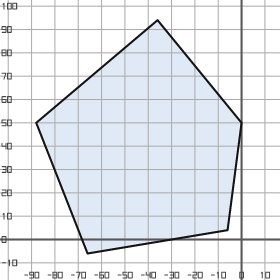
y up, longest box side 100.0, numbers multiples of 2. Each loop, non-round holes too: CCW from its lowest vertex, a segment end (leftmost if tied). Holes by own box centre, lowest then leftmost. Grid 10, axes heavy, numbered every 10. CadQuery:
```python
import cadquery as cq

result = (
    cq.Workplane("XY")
    .moveTo(-66.0, -6.0)
    .lineTo(-6.0, 4.0)
    .lineTo(0.0, 50.0)
    .lineTo(-36.0, 94.0)
    .lineTo(-88.0, 50.0)
    .close()
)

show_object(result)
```